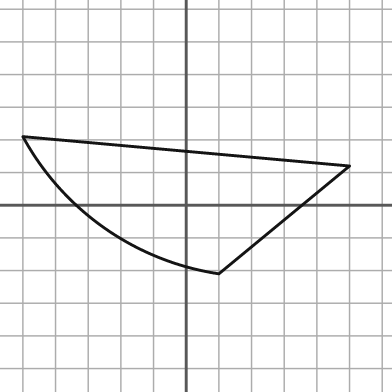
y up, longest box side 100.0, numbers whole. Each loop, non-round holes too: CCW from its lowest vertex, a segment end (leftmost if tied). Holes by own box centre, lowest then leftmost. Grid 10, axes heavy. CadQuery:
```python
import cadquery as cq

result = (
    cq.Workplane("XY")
    .moveTo(10.0, -21.0)
    .lineTo(50.0, 12.0)
    .lineTo(-50.0, 21.0)
    .threePointArc((-25.0, -7.0), (10.0, -21.0))
    .close()
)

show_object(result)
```